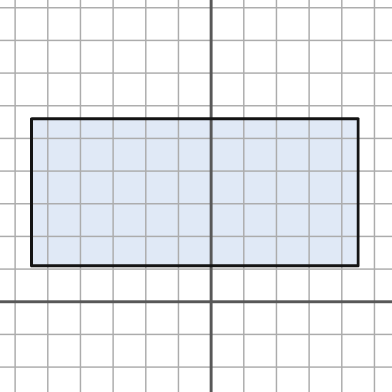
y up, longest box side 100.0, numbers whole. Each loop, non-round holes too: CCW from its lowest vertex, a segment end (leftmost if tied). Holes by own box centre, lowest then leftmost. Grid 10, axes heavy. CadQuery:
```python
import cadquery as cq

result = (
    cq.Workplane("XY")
    .moveTo(-55.0, 11.0)
    .lineTo(45.0, 11.0)
    .lineTo(45.0, 56.0)
    .lineTo(-55.0, 56.0)
    .close()
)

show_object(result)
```